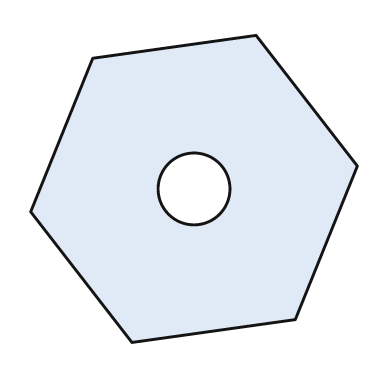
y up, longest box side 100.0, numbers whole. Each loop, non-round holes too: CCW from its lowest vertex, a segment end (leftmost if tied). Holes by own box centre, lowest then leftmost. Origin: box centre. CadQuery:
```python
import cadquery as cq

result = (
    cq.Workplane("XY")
    .moveTo(-19.0, -47.0)
    .lineTo(31.0, -40.0)
    .lineTo(50.0, 7.0)
    .lineTo(19.0, 47.0)
    .lineTo(-31.0, 40.0)
    .lineTo(-50.0, -7.0)
    .close()
    .moveTo(0.0, 0.0)
    .circle(11.0)
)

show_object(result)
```